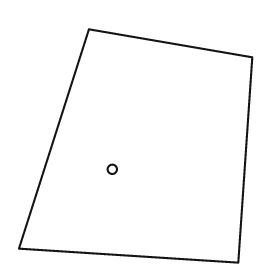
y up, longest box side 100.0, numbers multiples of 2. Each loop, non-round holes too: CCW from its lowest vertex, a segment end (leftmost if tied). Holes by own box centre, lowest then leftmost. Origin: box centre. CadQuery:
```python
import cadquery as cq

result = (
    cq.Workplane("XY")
    .moveTo(44.0, -50.0)
    .lineTo(50.0, 38.0)
    .lineTo(-20.0, 50.0)
    .lineTo(-50.0, -44.0)
    .close()
    .moveTo(-10.0, -10.0)
    .circle(2.0)
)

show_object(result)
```